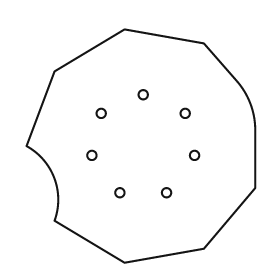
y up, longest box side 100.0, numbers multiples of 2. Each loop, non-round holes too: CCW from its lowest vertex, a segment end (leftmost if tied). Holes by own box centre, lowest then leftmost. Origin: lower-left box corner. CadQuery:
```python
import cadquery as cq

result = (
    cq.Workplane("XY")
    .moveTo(42.0, 0.0)
    .lineTo(76.0, 6.0)
    .lineTo(98.0, 32.0)
    .lineTo(98.0, 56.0)
    .threePointArc((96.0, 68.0), (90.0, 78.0))
    .lineTo(76.0, 94.0)
    .lineTo(42.0, 100.0)
    .lineTo(12.0, 82.0)
    .lineTo(0.0, 50.0)
    .threePointArc((12.0, 36.0), (12.0, 18.0))
    .close()
    .moveTo(40.0, 30.0)
    .circle(2.0)
    .moveTo(60.0, 30.0)
    .circle(2.0)
    .moveTo(28.0, 46.0)
    .circle(2.0)
    .moveTo(72.0, 46.0)
    .circle(2.0)
    .moveTo(32.0, 64.0)
    .circle(2.0)
    .moveTo(68.0, 64.0)
    .circle(2.0)
    .moveTo(50.0, 72.0)
    .circle(2.0)
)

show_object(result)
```